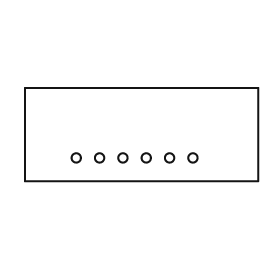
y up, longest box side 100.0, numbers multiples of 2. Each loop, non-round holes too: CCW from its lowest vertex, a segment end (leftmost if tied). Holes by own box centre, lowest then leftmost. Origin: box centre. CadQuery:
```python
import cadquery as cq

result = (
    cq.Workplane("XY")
    .moveTo(-50.0, -20.0)
    .lineTo(50.0, -20.0)
    .lineTo(50.0, 20.0)
    .lineTo(-50.0, 20.0)
    .close()
    .moveTo(-28.0, -10.0)
    .circle(2.0)
    .moveTo(-18.0, -10.0)
    .circle(2.0)
    .moveTo(-8.0, -10.0)
    .circle(2.0)
    .moveTo(2.0, -10.0)
    .circle(2.0)
    .moveTo(12.0, -10.0)
    .circle(2.0)
    .moveTo(22.0, -10.0)
    .circle(2.0)
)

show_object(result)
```